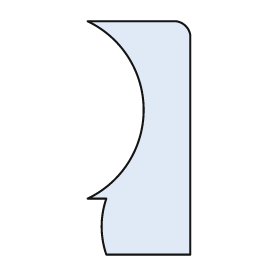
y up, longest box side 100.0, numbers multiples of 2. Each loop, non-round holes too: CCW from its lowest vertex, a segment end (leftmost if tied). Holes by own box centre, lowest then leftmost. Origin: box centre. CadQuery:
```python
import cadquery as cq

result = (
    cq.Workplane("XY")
    .moveTo(-14.0, -50.0)
    .lineTo(22.0, -50.0)
    .lineTo(22.0, 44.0)
    .threePointArc((20.0, 48.0), (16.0, 50.0))
    .lineTo(-22.0, 50.0)
    .threePointArc((2.0, 12.0), (-22.0, -26.0))
    .lineTo(-14.0, -26.0)
    .threePointArc((-16.0, -38.0), (-14.0, -50.0))
    .close()
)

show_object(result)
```